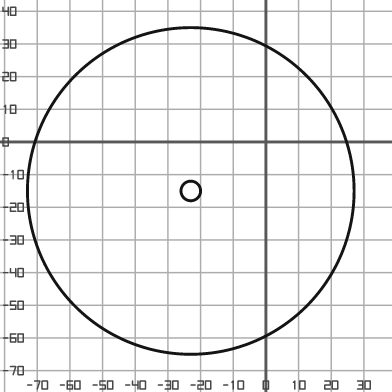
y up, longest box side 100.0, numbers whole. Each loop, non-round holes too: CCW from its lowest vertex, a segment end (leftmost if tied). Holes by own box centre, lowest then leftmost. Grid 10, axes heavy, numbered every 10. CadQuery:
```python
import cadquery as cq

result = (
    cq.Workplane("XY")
    .moveTo(-23.0, -15.0)
    .circle(50.0)
    .moveTo(-23.0, -15.0)
    .circle(3.0)
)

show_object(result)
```